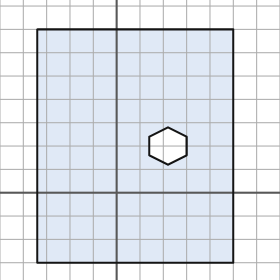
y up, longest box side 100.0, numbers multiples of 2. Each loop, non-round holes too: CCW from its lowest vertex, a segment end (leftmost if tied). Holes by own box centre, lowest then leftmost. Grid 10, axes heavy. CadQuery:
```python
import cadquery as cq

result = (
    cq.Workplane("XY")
    .moveTo(-34.0, -30.0)
    .lineTo(50.0, -30.0)
    .lineTo(50.0, 70.0)
    .lineTo(-34.0, 70.0)
    .close()
    .moveTo(22.0, 12.0)
    .lineTo(30.0, 16.0)
    .lineTo(30.0, 24.0)
    .lineTo(22.0, 28.0)
    .lineTo(14.0, 24.0)
    .lineTo(14.0, 16.0)
    .close()
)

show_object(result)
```